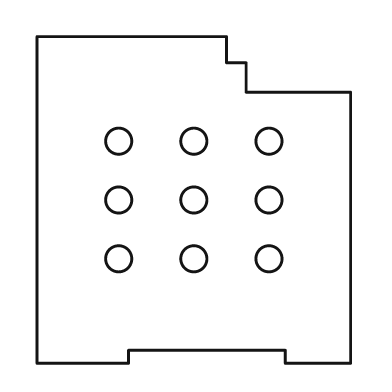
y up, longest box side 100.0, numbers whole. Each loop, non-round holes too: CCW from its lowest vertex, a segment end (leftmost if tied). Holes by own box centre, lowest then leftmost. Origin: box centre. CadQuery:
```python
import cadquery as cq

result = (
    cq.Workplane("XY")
    .moveTo(-48.0, -50.0)
    .lineTo(-20.0, -50.0)
    .lineTo(-20.0, -46.0)
    .lineTo(28.0, -46.0)
    .lineTo(28.0, -50.0)
    .lineTo(48.0, -50.0)
    .lineTo(48.0, 33.0)
    .lineTo(16.0, 33.0)
    .lineTo(16.0, 42.0)
    .lineTo(10.0, 42.0)
    .lineTo(10.0, 50.0)
    .lineTo(-48.0, 50.0)
    .close()
    .moveTo(-23.0, -18.0)
    .circle(4.0)
    .moveTo(0.0, -18.0)
    .circle(4.0)
    .moveTo(23.0, -18.0)
    .circle(4.0)
    .moveTo(-23.0, 0.0)
    .circle(4.0)
    .moveTo(0.0, 0.0)
    .circle(4.0)
    .moveTo(23.0, 0.0)
    .circle(4.0)
    .moveTo(-23.0, 18.0)
    .circle(4.0)
    .moveTo(0.0, 18.0)
    .circle(4.0)
    .moveTo(23.0, 18.0)
    .circle(4.0)
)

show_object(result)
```